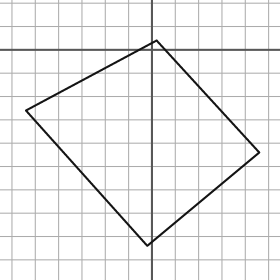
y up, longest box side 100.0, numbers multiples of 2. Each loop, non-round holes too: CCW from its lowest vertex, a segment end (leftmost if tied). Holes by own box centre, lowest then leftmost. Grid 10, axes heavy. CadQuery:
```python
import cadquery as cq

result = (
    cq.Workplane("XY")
    .moveTo(-2.0, -84.0)
    .lineTo(46.0, -44.0)
    .lineTo(2.0, 4.0)
    .lineTo(-54.0, -26.0)
    .close()
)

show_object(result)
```